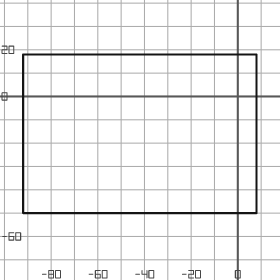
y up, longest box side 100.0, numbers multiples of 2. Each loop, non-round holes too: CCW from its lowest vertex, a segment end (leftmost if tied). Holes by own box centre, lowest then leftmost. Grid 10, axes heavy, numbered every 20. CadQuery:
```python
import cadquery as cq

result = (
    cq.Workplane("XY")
    .moveTo(-92.0, -50.0)
    .lineTo(8.0, -50.0)
    .lineTo(8.0, 18.0)
    .lineTo(-92.0, 18.0)
    .close()
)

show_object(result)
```